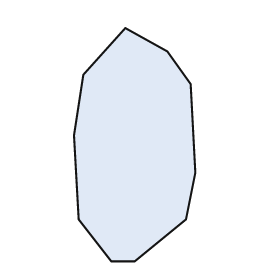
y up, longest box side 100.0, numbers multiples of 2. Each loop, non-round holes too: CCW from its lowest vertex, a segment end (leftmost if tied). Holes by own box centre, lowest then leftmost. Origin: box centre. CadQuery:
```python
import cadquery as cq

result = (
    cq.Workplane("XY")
    .moveTo(-10.0, -50.0)
    .lineTo(0.0, -50.0)
    .lineTo(22.0, -32.0)
    .lineTo(26.0, -12.0)
    .lineTo(24.0, 26.0)
    .lineTo(14.0, 40.0)
    .lineTo(-4.0, 50.0)
    .lineTo(-22.0, 30.0)
    .lineTo(-26.0, 4.0)
    .lineTo(-24.0, -32.0)
    .close()
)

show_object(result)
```